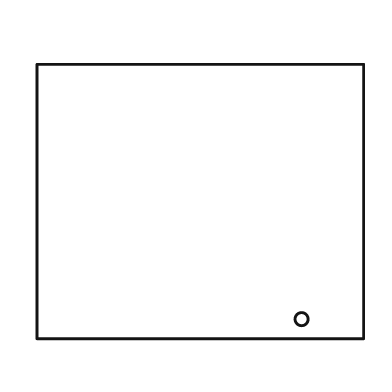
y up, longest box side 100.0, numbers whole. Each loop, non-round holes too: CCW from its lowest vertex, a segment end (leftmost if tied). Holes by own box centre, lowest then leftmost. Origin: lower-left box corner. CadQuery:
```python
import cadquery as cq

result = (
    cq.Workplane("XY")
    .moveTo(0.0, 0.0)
    .lineTo(100.0, 0.0)
    .lineTo(100.0, 84.0)
    .lineTo(0.0, 84.0)
    .close()
    .moveTo(81.0, 6.0)
    .circle(2.0)
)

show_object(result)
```